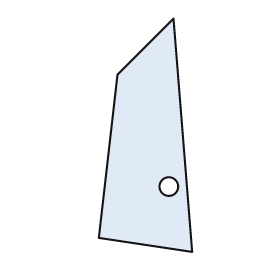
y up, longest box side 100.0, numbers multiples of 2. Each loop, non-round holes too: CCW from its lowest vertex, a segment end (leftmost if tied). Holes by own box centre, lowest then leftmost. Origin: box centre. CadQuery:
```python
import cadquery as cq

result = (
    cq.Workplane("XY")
    .moveTo(20.0, -50.0)
    .lineTo(12.0, 50.0)
    .lineTo(-12.0, 26.0)
    .lineTo(-20.0, -44.0)
    .close()
    .moveTo(10.0, -22.0)
    .circle(4.0)
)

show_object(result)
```